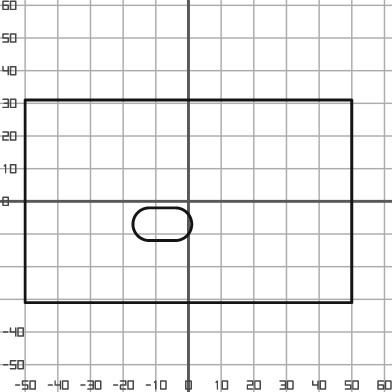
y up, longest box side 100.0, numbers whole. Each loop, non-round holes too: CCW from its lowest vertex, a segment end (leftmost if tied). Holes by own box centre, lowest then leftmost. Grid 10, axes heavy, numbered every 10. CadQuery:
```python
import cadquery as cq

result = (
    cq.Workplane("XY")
    .moveTo(-50.0, -31.0)
    .lineTo(50.0, -31.0)
    .lineTo(50.0, 31.0)
    .lineTo(-50.0, 31.0)
    .close()
    .moveTo(-12.0, -12.0)
    .lineTo(-4.0, -12.0)
    .threePointArc((1.0, -7.0), (-4.0, -2.0))
    .lineTo(-12.0, -2.0)
    .threePointArc((-17.0, -7.0), (-12.0, -12.0))
    .close()
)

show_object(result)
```